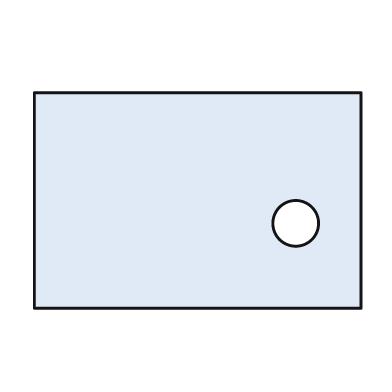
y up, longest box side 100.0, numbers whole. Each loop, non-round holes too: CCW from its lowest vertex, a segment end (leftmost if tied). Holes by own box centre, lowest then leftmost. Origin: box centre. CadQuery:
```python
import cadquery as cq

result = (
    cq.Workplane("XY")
    .moveTo(-50.0, -33.0)
    .lineTo(50.0, -33.0)
    .lineTo(50.0, 33.0)
    .lineTo(-50.0, 33.0)
    .close()
    .moveTo(30.0, -7.0)
    .circle(7.0)
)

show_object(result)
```